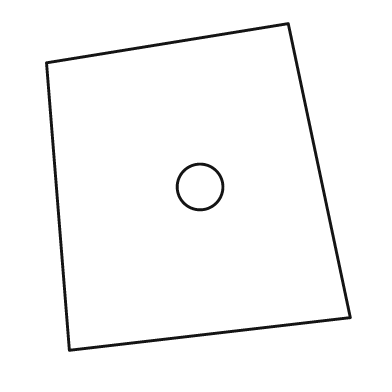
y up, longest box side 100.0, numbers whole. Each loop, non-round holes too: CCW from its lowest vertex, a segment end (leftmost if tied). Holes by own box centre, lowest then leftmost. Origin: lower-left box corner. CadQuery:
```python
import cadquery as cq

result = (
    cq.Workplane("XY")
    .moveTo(7.0, 0.0)
    .lineTo(93.0, 10.0)
    .lineTo(74.0, 100.0)
    .lineTo(0.0, 88.0)
    .close()
    .moveTo(47.0, 50.0)
    .circle(7.0)
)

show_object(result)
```